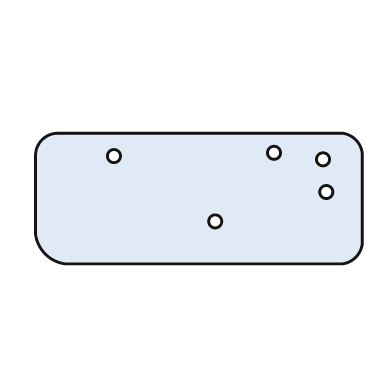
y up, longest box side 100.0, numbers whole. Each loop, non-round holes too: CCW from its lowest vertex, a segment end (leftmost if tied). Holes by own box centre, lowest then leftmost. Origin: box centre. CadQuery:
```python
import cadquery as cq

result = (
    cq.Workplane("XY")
    .moveTo(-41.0, -20.0)
    .lineTo(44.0, -20.0)
    .threePointArc((48.0, -18.0), (50.0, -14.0))
    .lineTo(50.0, 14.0)
    .threePointArc((48.0, 18.0), (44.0, 20.0))
    .lineTo(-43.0, 20.0)
    .threePointArc((-48.0, 18.0), (-50.0, 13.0))
    .lineTo(-50.0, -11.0)
    .threePointArc((-47.0, -17.0), (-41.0, -20.0))
    .close()
    .moveTo(5.0, -7.0)
    .circle(2.0)
    .moveTo(39.0, 2.0)
    .circle(2.0)
    .moveTo(38.0, 12.0)
    .circle(2.0)
    .moveTo(-26.0, 13.0)
    .circle(2.0)
    .moveTo(23.0, 14.0)
    .circle(2.0)
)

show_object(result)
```